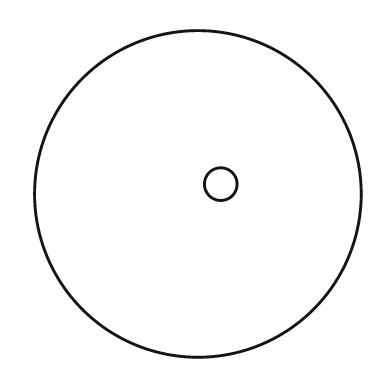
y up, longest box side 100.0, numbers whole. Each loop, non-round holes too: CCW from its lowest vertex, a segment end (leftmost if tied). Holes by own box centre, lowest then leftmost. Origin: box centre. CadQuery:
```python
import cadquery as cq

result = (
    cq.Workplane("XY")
    .moveTo(0.0, 0.0)
    .circle(50.0)
    .moveTo(7.0, 3.0)
    .circle(5.0)
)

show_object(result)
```